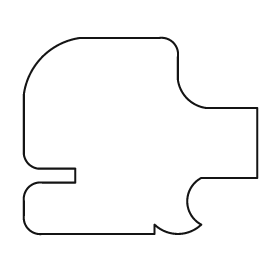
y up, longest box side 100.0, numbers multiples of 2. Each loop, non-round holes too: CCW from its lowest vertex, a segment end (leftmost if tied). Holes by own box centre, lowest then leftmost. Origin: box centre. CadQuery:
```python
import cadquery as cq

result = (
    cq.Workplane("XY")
    .moveTo(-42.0, -42.0)
    .lineTo(6.0, -42.0)
    .lineTo(6.0, -38.0)
    .threePointArc((16.0, -42.0), (26.0, -38.0))
    .threePointArc((20.0, -28.0), (26.0, -18.0))
    .lineTo(50.0, -18.0)
    .lineTo(50.0, 12.0)
    .lineTo(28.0, 12.0)
    .threePointArc((20.0, 16.0), (16.0, 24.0))
    .lineTo(16.0, 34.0)
    .threePointArc((14.0, 40.0), (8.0, 42.0))
    .lineTo(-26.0, 42.0)
    .threePointArc((-42.0, 34.0), (-50.0, 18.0))
    .lineTo(-50.0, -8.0)
    .threePointArc((-48.0, -12.0), (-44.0, -14.0))
    .lineTo(-28.0, -14.0)
    .lineTo(-28.0, -20.0)
    .lineTo(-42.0, -20.0)
    .threePointArc((-48.0, -22.0), (-50.0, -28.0))
    .lineTo(-50.0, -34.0)
    .threePointArc((-48.0, -40.0), (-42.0, -42.0))
    .close()
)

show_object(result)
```